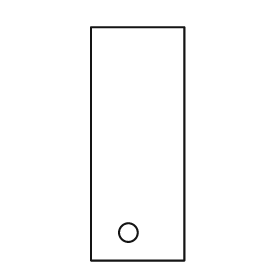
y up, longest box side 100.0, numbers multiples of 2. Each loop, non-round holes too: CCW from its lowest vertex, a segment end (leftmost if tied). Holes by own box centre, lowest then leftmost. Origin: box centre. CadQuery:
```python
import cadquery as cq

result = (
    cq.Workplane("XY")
    .moveTo(-20.0, -50.0)
    .lineTo(20.0, -50.0)
    .lineTo(20.0, 50.0)
    .lineTo(-20.0, 50.0)
    .close()
    .moveTo(-4.0, -38.0)
    .circle(4.0)
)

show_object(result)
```